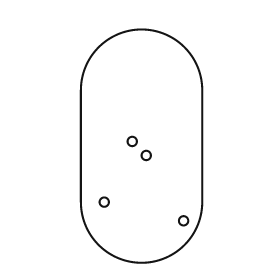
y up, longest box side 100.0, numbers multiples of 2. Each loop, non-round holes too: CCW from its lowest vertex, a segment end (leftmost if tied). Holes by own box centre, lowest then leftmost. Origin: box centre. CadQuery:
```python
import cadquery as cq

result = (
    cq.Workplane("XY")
    .moveTo(-26.0, -24.0)
    .threePointArc((0.0, -50.0), (26.0, -24.0))
    .lineTo(26.0, 24.0)
    .threePointArc((0.0, 50.0), (-26.0, 24.0))
    .close()
    .moveTo(18.0, -32.0)
    .circle(2.0)
    .moveTo(-16.0, -24.0)
    .circle(2.0)
    .moveTo(2.0, -4.0)
    .circle(2.0)
    .moveTo(-4.0, 2.0)
    .circle(2.0)
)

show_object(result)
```